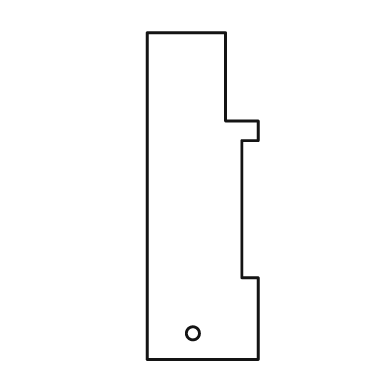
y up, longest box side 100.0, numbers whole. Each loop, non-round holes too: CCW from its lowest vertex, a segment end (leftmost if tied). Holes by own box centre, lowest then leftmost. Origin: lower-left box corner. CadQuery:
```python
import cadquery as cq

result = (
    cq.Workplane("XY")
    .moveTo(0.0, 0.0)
    .lineTo(34.0, 0.0)
    .lineTo(34.0, 25.0)
    .lineTo(29.0, 25.0)
    .lineTo(29.0, 67.0)
    .lineTo(34.0, 67.0)
    .lineTo(34.0, 73.0)
    .lineTo(24.0, 73.0)
    .lineTo(24.0, 100.0)
    .lineTo(0.0, 100.0)
    .close()
    .moveTo(14.0, 8.0)
    .circle(2.0)
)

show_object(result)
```